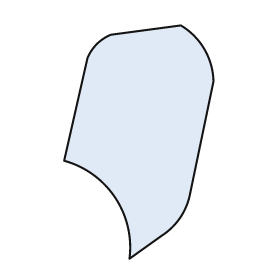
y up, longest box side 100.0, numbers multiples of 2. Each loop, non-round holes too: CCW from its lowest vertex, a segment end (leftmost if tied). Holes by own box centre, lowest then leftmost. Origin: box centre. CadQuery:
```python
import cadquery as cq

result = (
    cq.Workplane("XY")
    .moveTo(-4.0, -50.0)
    .lineTo(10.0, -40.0)
    .threePointArc((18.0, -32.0), (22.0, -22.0))
    .lineTo(32.0, 26.0)
    .threePointArc((28.0, 40.0), (18.0, 50.0))
    .lineTo(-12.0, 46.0)
    .threePointArc((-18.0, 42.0), (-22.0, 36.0))
    .lineTo(-32.0, -8.0)
    .threePointArc((-10.0, -24.0), (-4.0, -50.0))
    .close()
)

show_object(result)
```